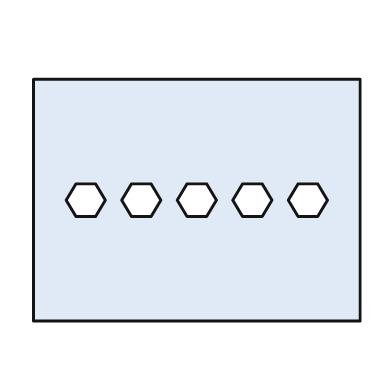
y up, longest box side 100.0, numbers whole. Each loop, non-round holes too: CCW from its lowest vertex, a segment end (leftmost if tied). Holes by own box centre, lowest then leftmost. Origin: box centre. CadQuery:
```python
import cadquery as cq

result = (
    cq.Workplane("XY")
    .moveTo(-50.0, -37.0)
    .lineTo(50.0, -37.0)
    .lineTo(50.0, 37.0)
    .lineTo(-50.0, 37.0)
    .close()
    .moveTo(-37.0, -5.0)
    .lineTo(-31.0, -5.0)
    .lineTo(-28.0, 0.0)
    .lineTo(-31.0, 5.0)
    .lineTo(-37.0, 5.0)
    .lineTo(-40.0, 0.0)
    .close()
    .moveTo(-20.0, -5.0)
    .lineTo(-14.0, -5.0)
    .lineTo(-11.0, 0.0)
    .lineTo(-14.0, 5.0)
    .lineTo(-20.0, 5.0)
    .lineTo(-23.0, 0.0)
    .close()
    .moveTo(-3.0, -5.0)
    .lineTo(3.0, -5.0)
    .lineTo(6.0, 0.0)
    .lineTo(3.0, 5.0)
    .lineTo(-3.0, 5.0)
    .lineTo(-6.0, 0.0)
    .close()
    .moveTo(14.0, -5.0)
    .lineTo(20.0, -5.0)
    .lineTo(23.0, 0.0)
    .lineTo(20.0, 5.0)
    .lineTo(14.0, 5.0)
    .lineTo(11.0, 0.0)
    .close()
    .moveTo(31.0, -5.0)
    .lineTo(37.0, -5.0)
    .lineTo(40.0, 0.0)
    .lineTo(37.0, 5.0)
    .lineTo(31.0, 5.0)
    .lineTo(28.0, 0.0)
    .close()
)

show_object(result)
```